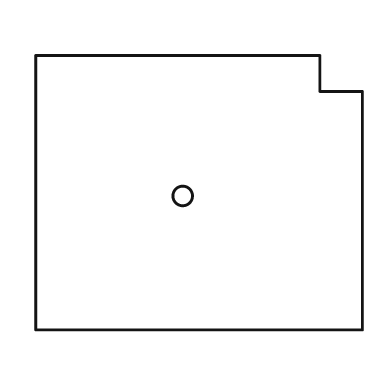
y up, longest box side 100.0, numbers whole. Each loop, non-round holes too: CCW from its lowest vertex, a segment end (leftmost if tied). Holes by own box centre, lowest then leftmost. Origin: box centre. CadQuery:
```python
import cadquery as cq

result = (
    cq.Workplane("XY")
    .moveTo(-50.0, -42.0)
    .lineTo(50.0, -42.0)
    .lineTo(50.0, 31.0)
    .lineTo(37.0, 31.0)
    .lineTo(37.0, 42.0)
    .lineTo(-50.0, 42.0)
    .close()
    .moveTo(-5.0, -1.0)
    .circle(3.0)
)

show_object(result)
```